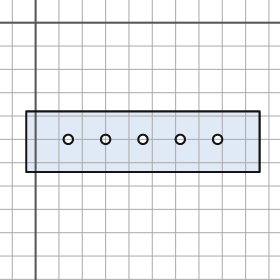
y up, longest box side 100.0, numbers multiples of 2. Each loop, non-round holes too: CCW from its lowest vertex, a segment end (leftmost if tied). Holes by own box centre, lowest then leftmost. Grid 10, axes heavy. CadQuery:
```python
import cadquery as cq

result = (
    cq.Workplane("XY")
    .moveTo(-4.0, -64.0)
    .lineTo(96.0, -64.0)
    .lineTo(96.0, -38.0)
    .lineTo(-4.0, -38.0)
    .close()
    .moveTo(14.0, -50.0)
    .circle(2.0)
    .moveTo(30.0, -50.0)
    .circle(2.0)
    .moveTo(46.0, -50.0)
    .circle(2.0)
    .moveTo(62.0, -50.0)
    .circle(2.0)
    .moveTo(78.0, -50.0)
    .circle(2.0)
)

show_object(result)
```